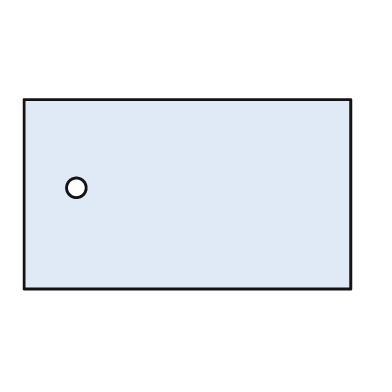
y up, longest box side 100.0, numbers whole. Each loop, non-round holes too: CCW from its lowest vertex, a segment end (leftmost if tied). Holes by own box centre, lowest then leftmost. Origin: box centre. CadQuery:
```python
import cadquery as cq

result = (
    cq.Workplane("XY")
    .moveTo(-50.0, -29.0)
    .lineTo(50.0, -29.0)
    .lineTo(50.0, 29.0)
    .lineTo(-50.0, 29.0)
    .close()
    .moveTo(-34.0, 2.0)
    .circle(3.0)
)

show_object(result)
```